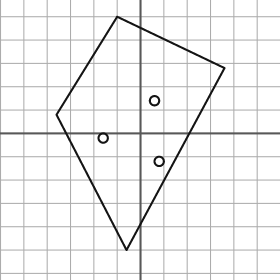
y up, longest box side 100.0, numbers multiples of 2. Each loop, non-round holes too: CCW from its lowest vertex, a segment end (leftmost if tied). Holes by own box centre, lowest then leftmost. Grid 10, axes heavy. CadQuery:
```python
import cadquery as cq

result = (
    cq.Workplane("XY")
    .moveTo(-6.0, -50.0)
    .lineTo(36.0, 28.0)
    .lineTo(-10.0, 50.0)
    .lineTo(-36.0, 8.0)
    .close()
    .moveTo(8.0, -12.0)
    .circle(2.0)
    .moveTo(-16.0, -2.0)
    .circle(2.0)
    .moveTo(6.0, 14.0)
    .circle(2.0)
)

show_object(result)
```